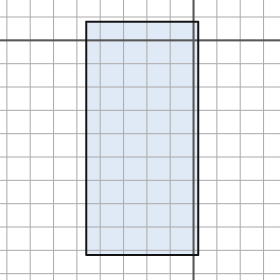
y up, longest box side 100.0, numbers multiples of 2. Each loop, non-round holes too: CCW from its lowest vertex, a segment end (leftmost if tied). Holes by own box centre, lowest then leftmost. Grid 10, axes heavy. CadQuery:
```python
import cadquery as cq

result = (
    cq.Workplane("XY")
    .moveTo(-46.0, -92.0)
    .lineTo(2.0, -92.0)
    .lineTo(2.0, 8.0)
    .lineTo(-46.0, 8.0)
    .close()
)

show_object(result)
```